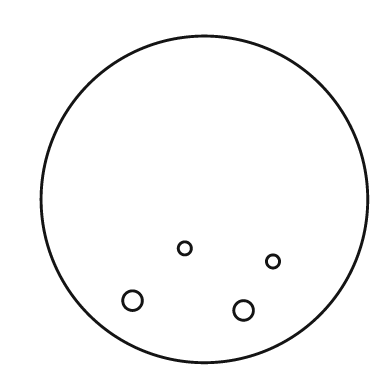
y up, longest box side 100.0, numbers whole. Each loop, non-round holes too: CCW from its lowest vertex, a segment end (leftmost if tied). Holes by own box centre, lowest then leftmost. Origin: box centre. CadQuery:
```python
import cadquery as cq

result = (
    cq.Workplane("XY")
    .moveTo(0.0, 0.0)
    .circle(50.0)
    .moveTo(12.0, -34.0)
    .circle(3.0)
    .moveTo(-22.0, -31.0)
    .circle(3.0)
    .moveTo(21.0, -19.0)
    .circle(2.0)
    .moveTo(-6.0, -15.0)
    .circle(2.0)
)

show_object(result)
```